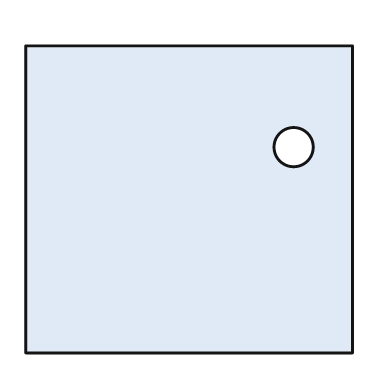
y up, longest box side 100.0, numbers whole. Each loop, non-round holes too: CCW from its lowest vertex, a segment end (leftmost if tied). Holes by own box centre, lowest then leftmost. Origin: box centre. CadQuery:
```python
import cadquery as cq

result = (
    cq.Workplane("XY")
    .moveTo(-50.0, -47.0)
    .lineTo(50.0, -47.0)
    .lineTo(50.0, 47.0)
    .lineTo(-50.0, 47.0)
    .close()
    .moveTo(32.0, 16.0)
    .circle(6.0)
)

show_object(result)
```